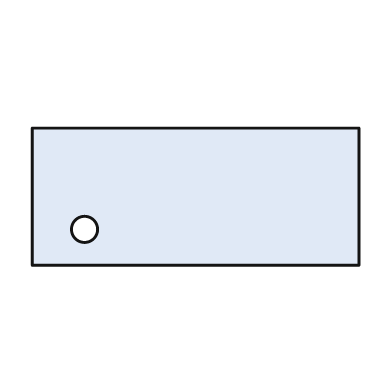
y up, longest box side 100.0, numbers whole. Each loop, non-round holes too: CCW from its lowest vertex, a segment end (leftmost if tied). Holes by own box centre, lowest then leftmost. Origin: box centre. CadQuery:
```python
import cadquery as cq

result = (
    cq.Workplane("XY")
    .moveTo(-50.0, -21.0)
    .lineTo(50.0, -21.0)
    .lineTo(50.0, 21.0)
    .lineTo(-50.0, 21.0)
    .close()
    .moveTo(-34.0, -10.0)
    .circle(4.0)
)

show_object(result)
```